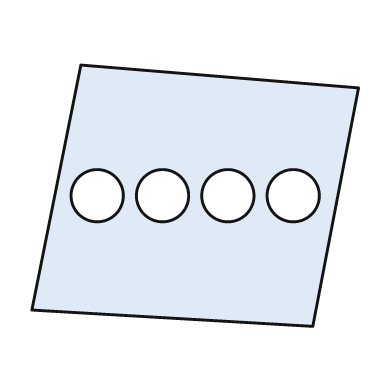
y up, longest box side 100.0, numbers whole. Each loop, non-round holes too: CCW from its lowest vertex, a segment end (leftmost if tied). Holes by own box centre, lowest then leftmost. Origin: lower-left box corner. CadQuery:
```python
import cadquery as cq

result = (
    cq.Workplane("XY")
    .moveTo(86.0, 0.0)
    .lineTo(100.0, 73.0)
    .lineTo(15.0, 80.0)
    .lineTo(0.0, 5.0)
    .close()
    .moveTo(20.0, 40.0)
    .circle(8.0)
    .moveTo(40.0, 40.0)
    .circle(8.0)
    .moveTo(60.0, 40.0)
    .circle(8.0)
    .moveTo(80.0, 40.0)
    .circle(8.0)
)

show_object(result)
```